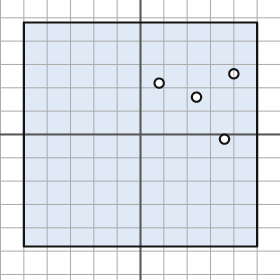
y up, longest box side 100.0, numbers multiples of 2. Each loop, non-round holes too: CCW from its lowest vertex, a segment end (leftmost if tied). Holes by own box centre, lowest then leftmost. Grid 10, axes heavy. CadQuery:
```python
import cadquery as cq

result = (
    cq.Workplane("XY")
    .moveTo(-50.0, -48.0)
    .lineTo(50.0, -48.0)
    .lineTo(50.0, 48.0)
    .lineTo(-50.0, 48.0)
    .close()
    .moveTo(36.0, -2.0)
    .circle(2.0)
    .moveTo(24.0, 16.0)
    .circle(2.0)
    .moveTo(8.0, 22.0)
    .circle(2.0)
    .moveTo(40.0, 26.0)
    .circle(2.0)
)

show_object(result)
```